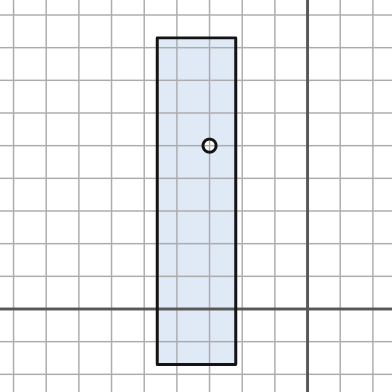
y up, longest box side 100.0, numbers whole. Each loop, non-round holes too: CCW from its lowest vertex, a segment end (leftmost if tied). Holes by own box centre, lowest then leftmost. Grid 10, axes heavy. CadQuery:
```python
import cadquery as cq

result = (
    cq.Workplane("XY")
    .moveTo(-46.0, -17.0)
    .lineTo(-22.0, -17.0)
    .lineTo(-22.0, 83.0)
    .lineTo(-46.0, 83.0)
    .close()
    .moveTo(-30.0, 50.0)
    .circle(2.0)
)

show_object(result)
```